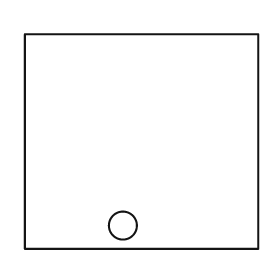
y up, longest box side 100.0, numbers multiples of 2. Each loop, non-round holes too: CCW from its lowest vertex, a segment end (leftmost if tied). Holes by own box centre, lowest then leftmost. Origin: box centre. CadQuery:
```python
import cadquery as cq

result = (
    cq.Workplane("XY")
    .moveTo(-50.0, -46.0)
    .lineTo(50.0, -46.0)
    .lineTo(50.0, 46.0)
    .lineTo(-50.0, 46.0)
    .close()
    .moveTo(-8.0, -36.0)
    .circle(6.0)
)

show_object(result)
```